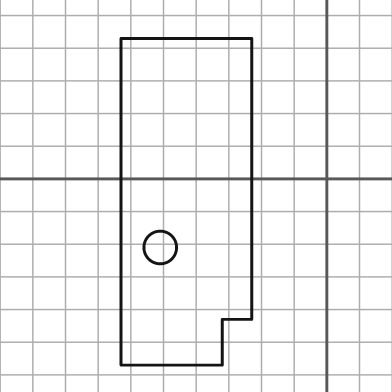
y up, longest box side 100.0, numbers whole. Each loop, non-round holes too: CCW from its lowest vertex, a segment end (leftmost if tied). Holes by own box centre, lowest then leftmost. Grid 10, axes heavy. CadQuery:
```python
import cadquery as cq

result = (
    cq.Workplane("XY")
    .moveTo(-63.0, -57.0)
    .lineTo(-32.0, -57.0)
    .lineTo(-32.0, -43.0)
    .lineTo(-23.0, -43.0)
    .lineTo(-23.0, 43.0)
    .lineTo(-63.0, 43.0)
    .close()
    .moveTo(-51.0, -21.0)
    .circle(5.0)
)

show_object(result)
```